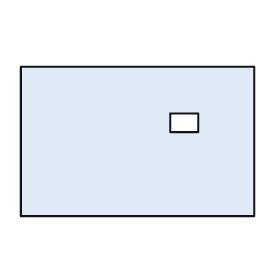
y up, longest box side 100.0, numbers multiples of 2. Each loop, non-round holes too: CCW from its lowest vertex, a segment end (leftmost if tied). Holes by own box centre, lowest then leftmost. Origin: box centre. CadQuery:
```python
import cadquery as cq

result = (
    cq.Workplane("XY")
    .moveTo(-50.0, -32.0)
    .lineTo(50.0, -32.0)
    .lineTo(50.0, 32.0)
    .lineTo(-50.0, 32.0)
    .close()
    .moveTo(14.0, 4.0)
    .lineTo(26.0, 4.0)
    .lineTo(26.0, 12.0)
    .lineTo(14.0, 12.0)
    .close()
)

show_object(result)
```